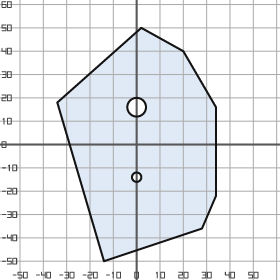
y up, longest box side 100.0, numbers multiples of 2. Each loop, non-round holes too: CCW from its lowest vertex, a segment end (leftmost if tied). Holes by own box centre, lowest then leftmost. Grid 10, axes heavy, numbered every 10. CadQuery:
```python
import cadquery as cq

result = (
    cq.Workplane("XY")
    .moveTo(-14.0, -50.0)
    .lineTo(28.0, -36.0)
    .lineTo(34.0, -22.0)
    .lineTo(34.0, 16.0)
    .lineTo(20.0, 40.0)
    .lineTo(2.0, 50.0)
    .lineTo(-34.0, 18.0)
    .close()
    .moveTo(0.0, -14.0)
    .circle(2.0)
    .moveTo(0.0, 16.0)
    .circle(4.0)
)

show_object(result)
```